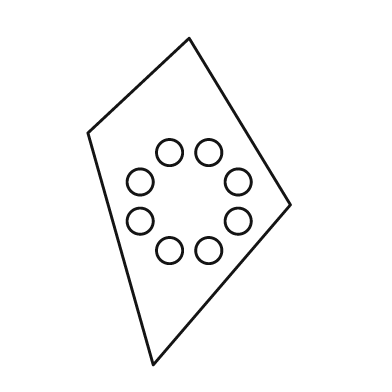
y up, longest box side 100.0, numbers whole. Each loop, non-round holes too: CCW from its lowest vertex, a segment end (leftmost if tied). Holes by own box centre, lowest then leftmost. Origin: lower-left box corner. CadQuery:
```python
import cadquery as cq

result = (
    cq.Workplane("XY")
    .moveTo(20.0, 0.0)
    .lineTo(62.0, 49.0)
    .lineTo(31.0, 100.0)
    .lineTo(0.0, 71.0)
    .close()
    .moveTo(25.0, 35.0)
    .circle(4.0)
    .moveTo(37.0, 35.0)
    .circle(4.0)
    .moveTo(16.0, 44.0)
    .circle(4.0)
    .moveTo(46.0, 44.0)
    .circle(4.0)
    .moveTo(16.0, 56.0)
    .circle(4.0)
    .moveTo(46.0, 56.0)
    .circle(4.0)
    .moveTo(25.0, 65.0)
    .circle(4.0)
    .moveTo(37.0, 65.0)
    .circle(4.0)
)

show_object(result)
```